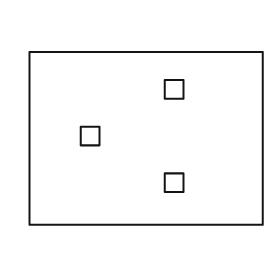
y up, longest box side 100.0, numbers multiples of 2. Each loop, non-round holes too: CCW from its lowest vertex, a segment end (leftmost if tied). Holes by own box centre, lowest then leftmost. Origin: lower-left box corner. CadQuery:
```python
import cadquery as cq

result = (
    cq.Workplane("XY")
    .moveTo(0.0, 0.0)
    .lineTo(100.0, 0.0)
    .lineTo(100.0, 74.0)
    .lineTo(0.0, 74.0)
    .close()
    .moveTo(58.0, 14.0)
    .lineTo(66.0, 14.0)
    .lineTo(66.0, 22.0)
    .lineTo(58.0, 22.0)
    .close()
    .moveTo(22.0, 34.0)
    .lineTo(30.0, 34.0)
    .lineTo(30.0, 42.0)
    .lineTo(22.0, 42.0)
    .close()
    .moveTo(58.0, 54.0)
    .lineTo(66.0, 54.0)
    .lineTo(66.0, 62.0)
    .lineTo(58.0, 62.0)
    .close()
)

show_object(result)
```